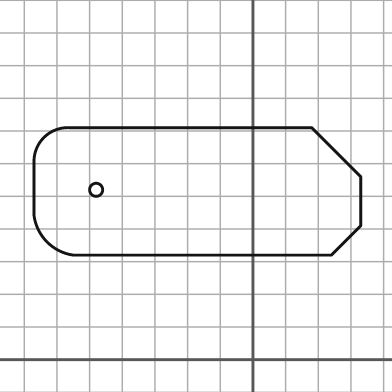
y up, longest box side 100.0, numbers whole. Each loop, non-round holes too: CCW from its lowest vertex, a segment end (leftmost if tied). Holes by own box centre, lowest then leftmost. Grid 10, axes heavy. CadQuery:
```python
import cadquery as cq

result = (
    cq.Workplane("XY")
    .moveTo(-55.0, 32.0)
    .lineTo(24.0, 32.0)
    .lineTo(33.0, 41.0)
    .lineTo(33.0, 56.0)
    .lineTo(18.0, 71.0)
    .lineTo(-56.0, 71.0)
    .threePointArc((-64.0, 68.0), (-67.0, 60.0))
    .lineTo(-67.0, 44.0)
    .threePointArc((-63.0, 36.0), (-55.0, 32.0))
    .close()
    .moveTo(-48.0, 52.0)
    .circle(2.0)
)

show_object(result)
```